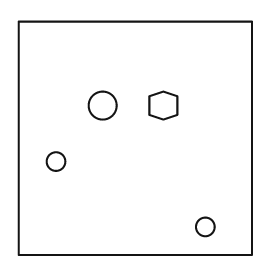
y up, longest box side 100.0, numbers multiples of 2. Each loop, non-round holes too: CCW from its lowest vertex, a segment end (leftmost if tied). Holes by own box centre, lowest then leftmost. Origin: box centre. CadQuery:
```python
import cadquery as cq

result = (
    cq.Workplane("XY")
    .moveTo(-50.0, -50.0)
    .lineTo(50.0, -50.0)
    .lineTo(50.0, 50.0)
    .lineTo(-50.0, 50.0)
    .close()
    .moveTo(30.0, -38.0)
    .circle(4.0)
    .moveTo(-34.0, -10.0)
    .circle(4.0)
    .moveTo(-14.0, 14.0)
    .circle(6.0)
    .moveTo(12.0, 8.0)
    .lineTo(18.0, 10.0)
    .lineTo(18.0, 18.0)
    .lineTo(12.0, 20.0)
    .lineTo(6.0, 18.0)
    .lineTo(6.0, 10.0)
    .close()
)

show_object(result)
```